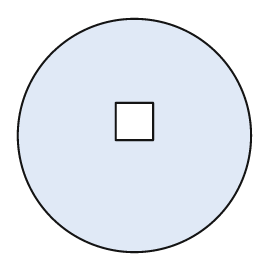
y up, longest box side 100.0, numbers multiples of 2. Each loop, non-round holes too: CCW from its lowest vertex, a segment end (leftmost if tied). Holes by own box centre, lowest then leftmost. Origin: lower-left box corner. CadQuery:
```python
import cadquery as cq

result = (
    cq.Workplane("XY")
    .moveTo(50.0, 50.0)
    .circle(50.0)
    .moveTo(42.0, 48.0)
    .lineTo(58.0, 48.0)
    .lineTo(58.0, 64.0)
    .lineTo(42.0, 64.0)
    .close()
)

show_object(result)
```